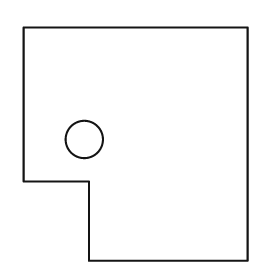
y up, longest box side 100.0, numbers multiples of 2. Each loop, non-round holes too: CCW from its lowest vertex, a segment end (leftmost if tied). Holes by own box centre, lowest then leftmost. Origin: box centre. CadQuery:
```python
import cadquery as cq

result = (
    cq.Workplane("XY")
    .moveTo(-20.0, -50.0)
    .lineTo(48.0, -50.0)
    .lineTo(48.0, 50.0)
    .lineTo(-48.0, 50.0)
    .lineTo(-48.0, -16.0)
    .lineTo(-20.0, -16.0)
    .close()
    .moveTo(-22.0, 2.0)
    .circle(8.0)
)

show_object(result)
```